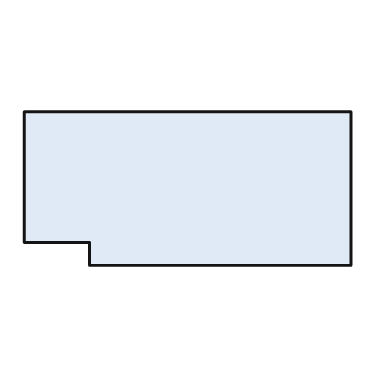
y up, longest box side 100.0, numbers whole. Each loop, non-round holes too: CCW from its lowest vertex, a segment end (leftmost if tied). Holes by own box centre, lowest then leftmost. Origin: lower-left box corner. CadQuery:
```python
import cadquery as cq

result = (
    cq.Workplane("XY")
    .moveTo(20.0, 0.0)
    .lineTo(100.0, 0.0)
    .lineTo(100.0, 47.0)
    .lineTo(0.0, 47.0)
    .lineTo(0.0, 7.0)
    .lineTo(20.0, 7.0)
    .close()
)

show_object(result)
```